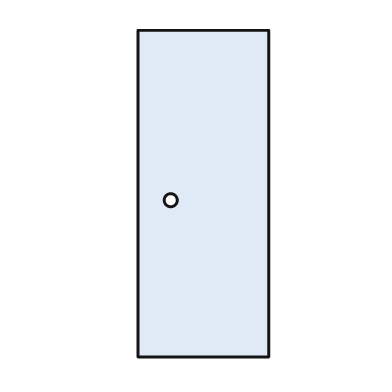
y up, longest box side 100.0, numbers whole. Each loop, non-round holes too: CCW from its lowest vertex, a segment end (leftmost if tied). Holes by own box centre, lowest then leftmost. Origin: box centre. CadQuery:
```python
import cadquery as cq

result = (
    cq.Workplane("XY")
    .moveTo(-20.0, -50.0)
    .lineTo(20.0, -50.0)
    .lineTo(20.0, 50.0)
    .lineTo(-20.0, 50.0)
    .close()
    .moveTo(-10.0, -2.0)
    .circle(2.0)
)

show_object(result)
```